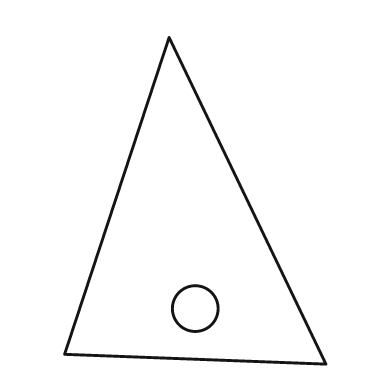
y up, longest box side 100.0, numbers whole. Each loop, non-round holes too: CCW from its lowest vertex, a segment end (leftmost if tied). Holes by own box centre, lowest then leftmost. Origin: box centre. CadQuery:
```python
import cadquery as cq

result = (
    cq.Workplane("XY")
    .moveTo(40.0, -50.0)
    .lineTo(-8.0, 50.0)
    .lineTo(-40.0, -47.0)
    .close()
    .moveTo(0.0, -33.0)
    .circle(7.0)
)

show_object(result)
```